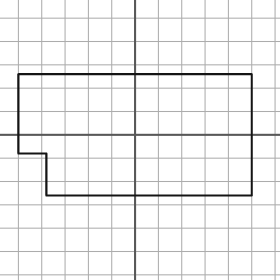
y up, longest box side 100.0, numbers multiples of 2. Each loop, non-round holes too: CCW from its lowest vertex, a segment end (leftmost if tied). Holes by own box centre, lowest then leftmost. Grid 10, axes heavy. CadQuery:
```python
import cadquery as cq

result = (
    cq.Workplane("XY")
    .moveTo(-38.0, -26.0)
    .lineTo(50.0, -26.0)
    .lineTo(50.0, 26.0)
    .lineTo(-50.0, 26.0)
    .lineTo(-50.0, -8.0)
    .lineTo(-38.0, -8.0)
    .close()
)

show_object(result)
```